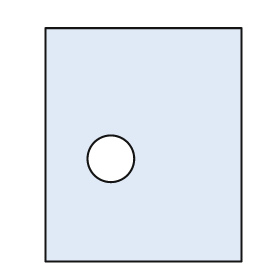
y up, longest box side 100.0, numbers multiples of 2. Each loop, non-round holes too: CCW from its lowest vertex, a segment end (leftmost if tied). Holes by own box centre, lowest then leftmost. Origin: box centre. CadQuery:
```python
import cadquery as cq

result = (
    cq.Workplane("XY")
    .moveTo(-42.0, -50.0)
    .lineTo(42.0, -50.0)
    .lineTo(42.0, 50.0)
    .lineTo(-42.0, 50.0)
    .close()
    .moveTo(-14.0, -6.0)
    .circle(10.0)
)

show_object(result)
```